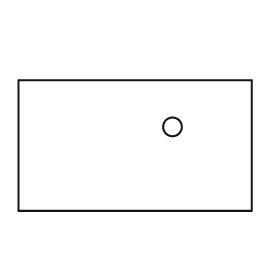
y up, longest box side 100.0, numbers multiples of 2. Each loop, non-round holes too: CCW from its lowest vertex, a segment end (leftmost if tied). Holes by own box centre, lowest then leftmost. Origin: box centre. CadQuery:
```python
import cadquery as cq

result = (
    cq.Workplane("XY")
    .moveTo(-50.0, -28.0)
    .lineTo(50.0, -28.0)
    .lineTo(50.0, 28.0)
    .lineTo(-50.0, 28.0)
    .close()
    .moveTo(16.0, 8.0)
    .circle(4.0)
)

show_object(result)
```